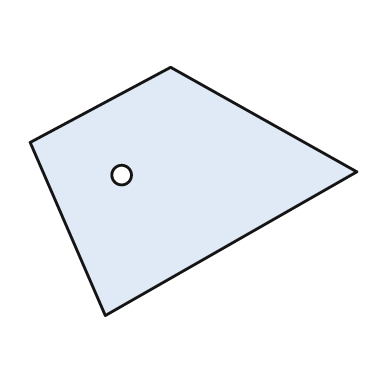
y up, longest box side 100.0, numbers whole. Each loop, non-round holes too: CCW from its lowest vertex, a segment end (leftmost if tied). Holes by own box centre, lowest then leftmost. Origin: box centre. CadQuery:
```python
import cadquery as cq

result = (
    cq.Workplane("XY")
    .moveTo(-27.0, -38.0)
    .lineTo(50.0, 6.0)
    .lineTo(-7.0, 38.0)
    .lineTo(-50.0, 15.0)
    .close()
    .moveTo(-22.0, 5.0)
    .circle(3.0)
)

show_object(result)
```